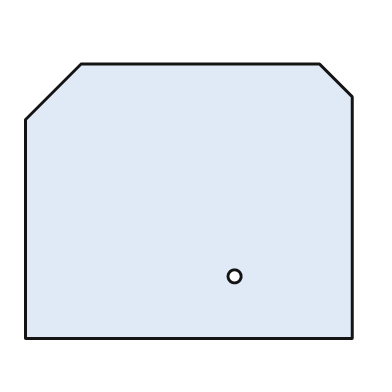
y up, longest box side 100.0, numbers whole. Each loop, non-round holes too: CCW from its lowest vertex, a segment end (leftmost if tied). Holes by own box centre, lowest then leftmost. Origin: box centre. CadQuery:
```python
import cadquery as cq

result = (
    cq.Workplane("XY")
    .moveTo(-50.0, -42.0)
    .lineTo(50.0, -42.0)
    .lineTo(50.0, 32.0)
    .lineTo(40.0, 42.0)
    .lineTo(-33.0, 42.0)
    .lineTo(-50.0, 25.0)
    .close()
    .moveTo(14.0, -23.0)
    .circle(2.0)
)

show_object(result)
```